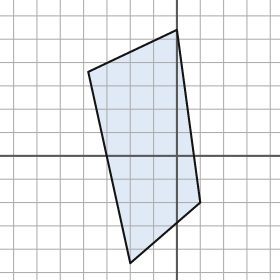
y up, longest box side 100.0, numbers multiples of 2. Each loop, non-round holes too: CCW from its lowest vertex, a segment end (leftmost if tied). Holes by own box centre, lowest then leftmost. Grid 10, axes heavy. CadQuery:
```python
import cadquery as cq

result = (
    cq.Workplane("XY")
    .moveTo(-20.0, -46.0)
    .lineTo(10.0, -20.0)
    .lineTo(0.0, 54.0)
    .lineTo(-38.0, 36.0)
    .close()
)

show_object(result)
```